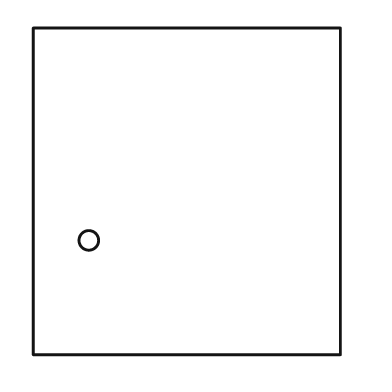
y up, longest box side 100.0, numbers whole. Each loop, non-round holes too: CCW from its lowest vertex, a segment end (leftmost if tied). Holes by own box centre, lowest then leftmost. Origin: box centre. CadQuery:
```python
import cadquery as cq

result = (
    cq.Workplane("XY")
    .moveTo(-47.0, -50.0)
    .lineTo(47.0, -50.0)
    .lineTo(47.0, 50.0)
    .lineTo(-47.0, 50.0)
    .close()
    .moveTo(-30.0, -15.0)
    .circle(3.0)
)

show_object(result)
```